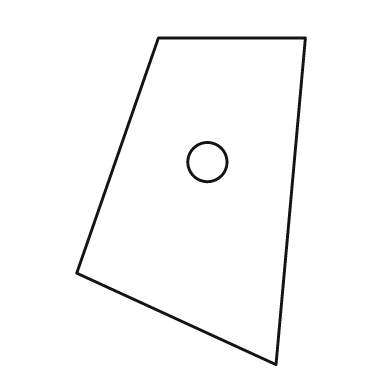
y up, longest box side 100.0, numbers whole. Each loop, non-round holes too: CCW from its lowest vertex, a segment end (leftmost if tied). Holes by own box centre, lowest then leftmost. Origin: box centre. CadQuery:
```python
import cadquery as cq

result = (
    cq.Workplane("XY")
    .moveTo(26.0, -50.0)
    .lineTo(35.0, 50.0)
    .lineTo(-10.0, 50.0)
    .lineTo(-35.0, -22.0)
    .close()
    .moveTo(5.0, 12.0)
    .circle(6.0)
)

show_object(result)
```